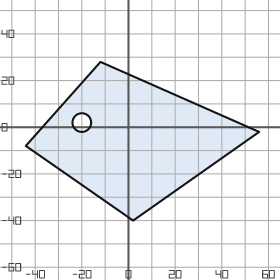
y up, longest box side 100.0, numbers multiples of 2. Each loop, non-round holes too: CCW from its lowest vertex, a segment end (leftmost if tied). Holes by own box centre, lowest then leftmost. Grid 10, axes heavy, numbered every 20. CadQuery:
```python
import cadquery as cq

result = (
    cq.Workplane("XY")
    .moveTo(2.0, -40.0)
    .lineTo(56.0, -2.0)
    .lineTo(-12.0, 28.0)
    .lineTo(-44.0, -8.0)
    .close()
    .moveTo(-20.0, 2.0)
    .circle(4.0)
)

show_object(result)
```